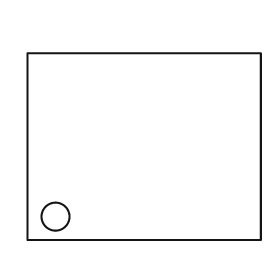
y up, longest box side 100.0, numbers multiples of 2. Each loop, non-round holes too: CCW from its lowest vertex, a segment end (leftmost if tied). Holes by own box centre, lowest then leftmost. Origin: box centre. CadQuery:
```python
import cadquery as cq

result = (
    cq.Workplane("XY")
    .moveTo(-50.0, -40.0)
    .lineTo(50.0, -40.0)
    .lineTo(50.0, 40.0)
    .lineTo(-50.0, 40.0)
    .close()
    .moveTo(-38.0, -30.0)
    .circle(6.0)
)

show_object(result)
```